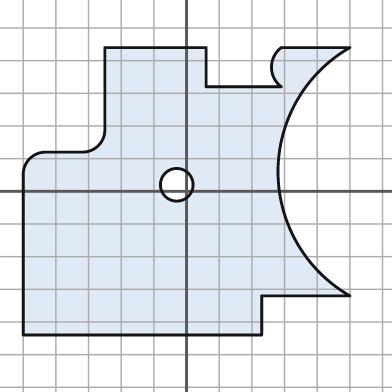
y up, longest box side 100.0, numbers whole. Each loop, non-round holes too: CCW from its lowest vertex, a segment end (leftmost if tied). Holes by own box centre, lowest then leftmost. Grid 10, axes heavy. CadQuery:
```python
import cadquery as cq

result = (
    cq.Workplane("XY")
    .moveTo(-50.0, -44.0)
    .lineTo(23.0, -44.0)
    .lineTo(23.0, -32.0)
    .lineTo(50.0, -32.0)
    .threePointArc((28.0, 6.0), (50.0, 44.0))
    .lineTo(29.0, 44.0)
    .threePointArc((26.0, 38.0), (29.0, 32.0))
    .lineTo(6.0, 32.0)
    .lineTo(6.0, 44.0)
    .lineTo(-25.0, 44.0)
    .lineTo(-25.0, 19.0)
    .threePointArc((-27.0, 14.0), (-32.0, 12.0))
    .lineTo(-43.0, 12.0)
    .threePointArc((-48.0, 10.0), (-50.0, 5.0))
    .close()
    .moveTo(-3.0, 2.0)
    .circle(5.0)
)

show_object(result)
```